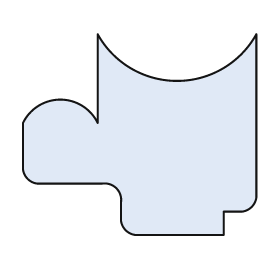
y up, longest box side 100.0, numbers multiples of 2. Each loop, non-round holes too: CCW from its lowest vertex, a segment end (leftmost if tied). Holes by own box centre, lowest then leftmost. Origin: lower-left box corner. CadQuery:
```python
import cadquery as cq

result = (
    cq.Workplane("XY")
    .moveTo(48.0, 0.0)
    .lineTo(86.0, 0.0)
    .lineTo(86.0, 10.0)
    .lineTo(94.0, 10.0)
    .threePointArc((98.0, 12.0), (100.0, 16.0))
    .lineTo(100.0, 86.0)
    .threePointArc((66.0, 66.0), (32.0, 86.0))
    .lineTo(32.0, 48.0)
    .threePointArc((16.0, 58.0), (0.0, 48.0))
    .lineTo(0.0, 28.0)
    .threePointArc((2.0, 24.0), (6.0, 22.0))
    .lineTo(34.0, 22.0)
    .threePointArc((40.0, 20.0), (42.0, 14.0))
    .lineTo(42.0, 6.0)
    .threePointArc((44.0, 2.0), (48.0, 0.0))
    .close()
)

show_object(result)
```